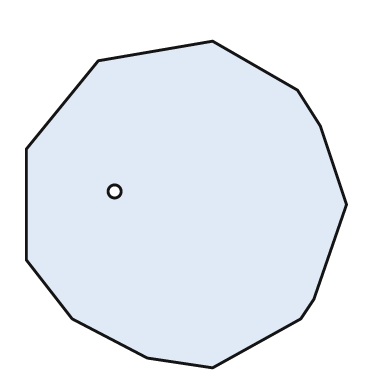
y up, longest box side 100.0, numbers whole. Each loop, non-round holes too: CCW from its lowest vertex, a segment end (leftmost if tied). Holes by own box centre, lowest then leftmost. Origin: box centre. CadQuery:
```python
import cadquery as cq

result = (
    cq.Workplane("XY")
    .moveTo(8.0, -50.0)
    .lineTo(35.0, -35.0)
    .lineTo(39.0, -29.0)
    .lineTo(49.0, 0.0)
    .lineTo(41.0, 24.0)
    .lineTo(34.0, 35.0)
    .lineTo(8.0, 50.0)
    .lineTo(-27.0, 44.0)
    .lineTo(-49.0, 17.0)
    .lineTo(-49.0, -17.0)
    .lineTo(-35.0, -35.0)
    .lineTo(-12.0, -47.0)
    .close()
    .moveTo(-22.0, 4.0)
    .circle(2.0)
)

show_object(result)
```